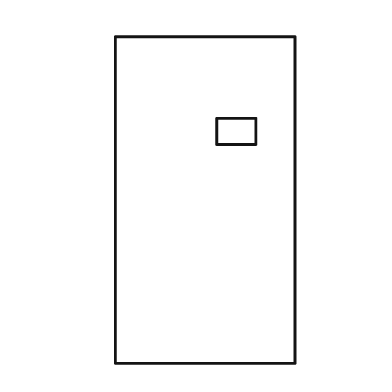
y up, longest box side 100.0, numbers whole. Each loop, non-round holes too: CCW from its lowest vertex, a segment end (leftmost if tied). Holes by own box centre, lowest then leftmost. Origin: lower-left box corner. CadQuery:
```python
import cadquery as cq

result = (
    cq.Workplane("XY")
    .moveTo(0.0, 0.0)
    .lineTo(55.0, 0.0)
    .lineTo(55.0, 100.0)
    .lineTo(0.0, 100.0)
    .close()
    .moveTo(31.0, 67.0)
    .lineTo(43.0, 67.0)
    .lineTo(43.0, 75.0)
    .lineTo(31.0, 75.0)
    .close()
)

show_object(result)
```